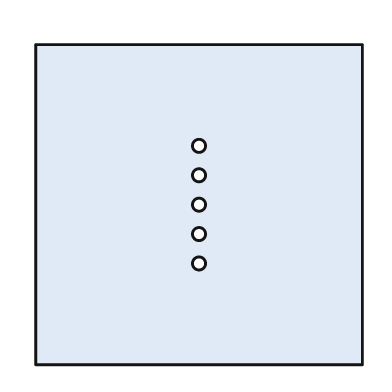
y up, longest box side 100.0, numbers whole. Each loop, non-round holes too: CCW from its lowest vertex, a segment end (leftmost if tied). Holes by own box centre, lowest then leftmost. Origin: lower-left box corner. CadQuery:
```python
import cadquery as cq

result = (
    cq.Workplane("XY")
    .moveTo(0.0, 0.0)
    .lineTo(100.0, 0.0)
    .lineTo(100.0, 98.0)
    .lineTo(0.0, 98.0)
    .close()
    .moveTo(50.0, 31.0)
    .circle(2.0)
    .moveTo(50.0, 40.0)
    .circle(2.0)
    .moveTo(50.0, 49.0)
    .circle(2.0)
    .moveTo(50.0, 58.0)
    .circle(2.0)
    .moveTo(50.0, 67.0)
    .circle(2.0)
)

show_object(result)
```